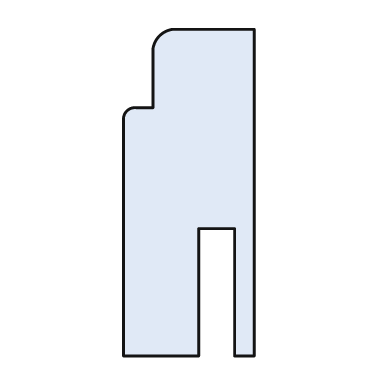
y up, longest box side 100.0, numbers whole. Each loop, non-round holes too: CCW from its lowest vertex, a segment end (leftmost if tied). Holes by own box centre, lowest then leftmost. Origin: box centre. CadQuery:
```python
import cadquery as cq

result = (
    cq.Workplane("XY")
    .moveTo(-20.0, -50.0)
    .lineTo(3.0, -50.0)
    .lineTo(3.0, -11.0)
    .lineTo(14.0, -11.0)
    .lineTo(14.0, -50.0)
    .lineTo(20.0, -50.0)
    .lineTo(20.0, 50.0)
    .lineTo(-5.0, 50.0)
    .threePointArc((-9.0, 48.0), (-11.0, 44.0))
    .lineTo(-11.0, 26.0)
    .lineTo(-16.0, 26.0)
    .threePointArc((-19.0, 25.0), (-20.0, 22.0))
    .close()
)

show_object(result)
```